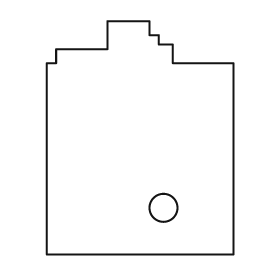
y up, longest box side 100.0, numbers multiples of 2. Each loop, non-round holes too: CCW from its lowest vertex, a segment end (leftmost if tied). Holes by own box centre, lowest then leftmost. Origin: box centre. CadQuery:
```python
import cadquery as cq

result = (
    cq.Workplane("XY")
    .moveTo(-40.0, -50.0)
    .lineTo(40.0, -50.0)
    .lineTo(40.0, 32.0)
    .lineTo(14.0, 32.0)
    .lineTo(14.0, 40.0)
    .lineTo(8.0, 40.0)
    .lineTo(8.0, 44.0)
    .lineTo(4.0, 44.0)
    .lineTo(4.0, 50.0)
    .lineTo(-14.0, 50.0)
    .lineTo(-14.0, 38.0)
    .lineTo(-36.0, 38.0)
    .lineTo(-36.0, 32.0)
    .lineTo(-40.0, 32.0)
    .close()
    .moveTo(10.0, -30.0)
    .circle(6.0)
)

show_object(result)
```